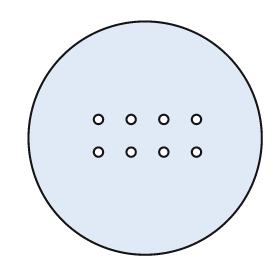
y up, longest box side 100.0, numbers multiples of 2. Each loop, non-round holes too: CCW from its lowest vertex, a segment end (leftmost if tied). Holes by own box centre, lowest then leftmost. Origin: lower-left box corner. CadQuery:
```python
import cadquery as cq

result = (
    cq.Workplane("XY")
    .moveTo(50.0, 50.0)
    .circle(50.0)
    .moveTo(30.0, 44.0)
    .circle(2.0)
    .moveTo(44.0, 44.0)
    .circle(2.0)
    .moveTo(58.0, 44.0)
    .circle(2.0)
    .moveTo(72.0, 44.0)
    .circle(2.0)
    .moveTo(30.0, 58.0)
    .circle(2.0)
    .moveTo(44.0, 58.0)
    .circle(2.0)
    .moveTo(58.0, 58.0)
    .circle(2.0)
    .moveTo(72.0, 58.0)
    .circle(2.0)
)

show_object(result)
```